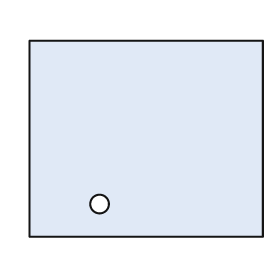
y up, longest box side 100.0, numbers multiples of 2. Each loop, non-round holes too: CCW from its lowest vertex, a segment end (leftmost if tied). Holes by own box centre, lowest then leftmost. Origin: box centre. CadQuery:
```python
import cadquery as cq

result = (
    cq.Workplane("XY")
    .moveTo(-50.0, -42.0)
    .lineTo(50.0, -42.0)
    .lineTo(50.0, 42.0)
    .lineTo(-50.0, 42.0)
    .close()
    .moveTo(-20.0, -28.0)
    .circle(4.0)
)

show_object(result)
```